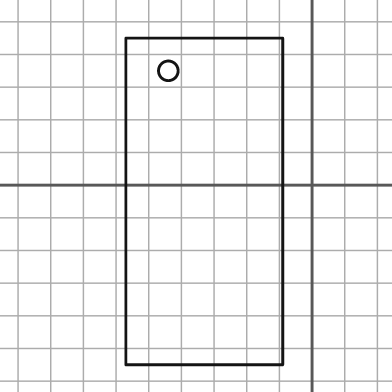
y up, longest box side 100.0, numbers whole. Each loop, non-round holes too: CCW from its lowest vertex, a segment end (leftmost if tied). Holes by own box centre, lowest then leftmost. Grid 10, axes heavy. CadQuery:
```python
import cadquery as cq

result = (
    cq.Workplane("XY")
    .moveTo(-57.0, -55.0)
    .lineTo(-9.0, -55.0)
    .lineTo(-9.0, 45.0)
    .lineTo(-57.0, 45.0)
    .close()
    .moveTo(-44.0, 35.0)
    .circle(3.0)
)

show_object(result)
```